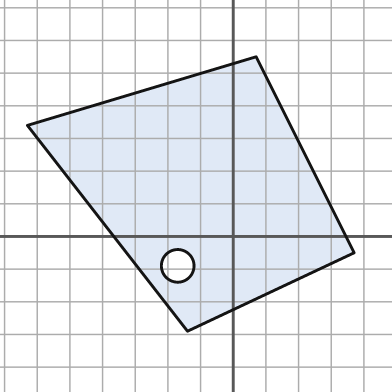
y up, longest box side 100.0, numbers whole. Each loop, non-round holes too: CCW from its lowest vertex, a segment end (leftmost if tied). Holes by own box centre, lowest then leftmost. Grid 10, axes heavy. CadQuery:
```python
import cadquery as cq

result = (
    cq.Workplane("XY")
    .moveTo(-14.0, -29.0)
    .lineTo(37.0, -5.0)
    .lineTo(7.0, 55.0)
    .lineTo(-63.0, 34.0)
    .close()
    .moveTo(-17.0, -9.0)
    .circle(5.0)
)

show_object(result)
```